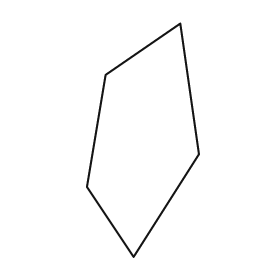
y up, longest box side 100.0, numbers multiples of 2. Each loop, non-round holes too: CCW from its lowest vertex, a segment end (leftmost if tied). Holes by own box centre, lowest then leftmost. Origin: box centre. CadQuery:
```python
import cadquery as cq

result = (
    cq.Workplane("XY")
    .moveTo(-4.0, -50.0)
    .lineTo(24.0, -6.0)
    .lineTo(16.0, 50.0)
    .lineTo(-16.0, 28.0)
    .lineTo(-24.0, -20.0)
    .close()
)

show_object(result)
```